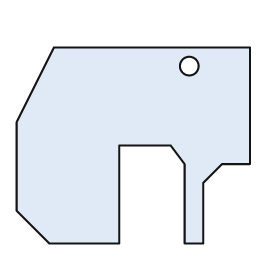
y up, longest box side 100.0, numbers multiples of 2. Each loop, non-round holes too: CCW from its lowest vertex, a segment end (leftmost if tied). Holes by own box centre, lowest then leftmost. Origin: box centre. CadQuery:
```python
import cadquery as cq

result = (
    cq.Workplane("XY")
    .moveTo(-36.0, -42.0)
    .lineTo(-6.0, -42.0)
    .lineTo(-6.0, 0.0)
    .lineTo(16.0, 0.0)
    .lineTo(22.0, -8.0)
    .lineTo(22.0, -42.0)
    .lineTo(30.0, -42.0)
    .lineTo(30.0, -16.0)
    .lineTo(38.0, -8.0)
    .lineTo(50.0, -8.0)
    .lineTo(50.0, 42.0)
    .lineTo(-34.0, 42.0)
    .lineTo(-50.0, 10.0)
    .lineTo(-50.0, -28.0)
    .close()
    .moveTo(24.0, 34.0)
    .circle(4.0)
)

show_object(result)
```